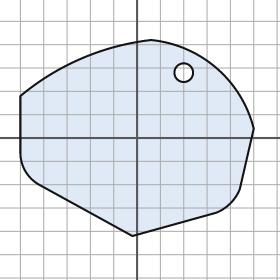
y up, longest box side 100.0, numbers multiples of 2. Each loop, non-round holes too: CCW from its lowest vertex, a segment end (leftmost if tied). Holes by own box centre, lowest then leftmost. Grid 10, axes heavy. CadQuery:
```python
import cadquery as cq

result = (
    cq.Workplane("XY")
    .moveTo(-2.0, -42.0)
    .lineTo(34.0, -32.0)
    .threePointArc((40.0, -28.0), (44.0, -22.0))
    .lineTo(50.0, 4.0)
    .threePointArc((34.0, 30.0), (6.0, 42.0))
    .threePointArc((-24.0, 34.0), (-50.0, 18.0))
    .lineTo(-50.0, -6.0)
    .threePointArc((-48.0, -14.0), (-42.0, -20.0))
    .close()
    .moveTo(20.0, 28.0)
    .circle(4.0)
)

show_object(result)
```